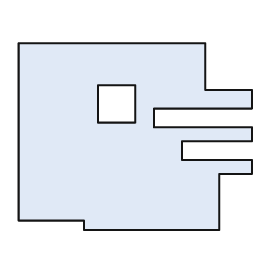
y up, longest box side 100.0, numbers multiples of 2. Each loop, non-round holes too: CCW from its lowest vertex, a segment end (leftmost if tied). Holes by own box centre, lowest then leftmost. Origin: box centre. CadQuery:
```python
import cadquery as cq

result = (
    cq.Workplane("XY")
    .moveTo(-22.0, -40.0)
    .lineTo(36.0, -40.0)
    .lineTo(36.0, -16.0)
    .lineTo(50.0, -16.0)
    .lineTo(50.0, -10.0)
    .lineTo(20.0, -10.0)
    .lineTo(20.0, -2.0)
    .lineTo(50.0, -2.0)
    .lineTo(50.0, 4.0)
    .lineTo(8.0, 4.0)
    .lineTo(8.0, 12.0)
    .lineTo(50.0, 12.0)
    .lineTo(50.0, 20.0)
    .lineTo(30.0, 20.0)
    .lineTo(30.0, 40.0)
    .lineTo(-50.0, 40.0)
    .lineTo(-50.0, -36.0)
    .lineTo(-22.0, -36.0)
    .close()
    .moveTo(-16.0, 6.0)
    .lineTo(0.0, 6.0)
    .lineTo(0.0, 22.0)
    .lineTo(-16.0, 22.0)
    .close()
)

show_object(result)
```